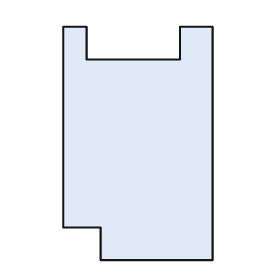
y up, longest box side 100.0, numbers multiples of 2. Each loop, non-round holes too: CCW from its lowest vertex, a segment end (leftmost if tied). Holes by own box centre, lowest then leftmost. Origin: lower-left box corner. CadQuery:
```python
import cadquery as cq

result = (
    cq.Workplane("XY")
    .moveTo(16.0, 0.0)
    .lineTo(64.0, 0.0)
    .lineTo(64.0, 100.0)
    .lineTo(50.0, 100.0)
    .lineTo(50.0, 86.0)
    .lineTo(10.0, 86.0)
    .lineTo(10.0, 100.0)
    .lineTo(0.0, 100.0)
    .lineTo(0.0, 14.0)
    .lineTo(16.0, 14.0)
    .close()
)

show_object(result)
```